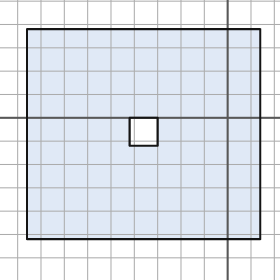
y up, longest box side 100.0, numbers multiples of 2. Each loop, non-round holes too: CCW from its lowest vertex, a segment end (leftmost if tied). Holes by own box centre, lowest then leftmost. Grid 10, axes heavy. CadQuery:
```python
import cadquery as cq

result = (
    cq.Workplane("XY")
    .moveTo(-86.0, -52.0)
    .lineTo(14.0, -52.0)
    .lineTo(14.0, 38.0)
    .lineTo(-86.0, 38.0)
    .close()
    .moveTo(-42.0, -12.0)
    .lineTo(-30.0, -12.0)
    .lineTo(-30.0, 0.0)
    .lineTo(-42.0, 0.0)
    .close()
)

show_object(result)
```